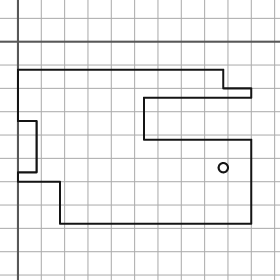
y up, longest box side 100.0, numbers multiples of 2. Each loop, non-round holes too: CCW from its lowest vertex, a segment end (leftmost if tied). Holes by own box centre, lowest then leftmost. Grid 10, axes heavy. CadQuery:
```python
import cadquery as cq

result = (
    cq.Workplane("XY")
    .moveTo(18.0, -78.0)
    .lineTo(100.0, -78.0)
    .lineTo(100.0, -42.0)
    .lineTo(54.0, -42.0)
    .lineTo(54.0, -24.0)
    .lineTo(100.0, -24.0)
    .lineTo(100.0, -20.0)
    .lineTo(88.0, -20.0)
    .lineTo(88.0, -12.0)
    .lineTo(0.0, -12.0)
    .lineTo(0.0, -34.0)
    .lineTo(8.0, -34.0)
    .lineTo(8.0, -56.0)
    .lineTo(0.0, -56.0)
    .lineTo(0.0, -60.0)
    .lineTo(18.0, -60.0)
    .close()
    .moveTo(88.0, -54.0)
    .circle(2.0)
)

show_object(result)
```